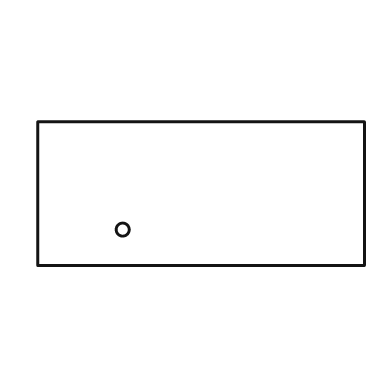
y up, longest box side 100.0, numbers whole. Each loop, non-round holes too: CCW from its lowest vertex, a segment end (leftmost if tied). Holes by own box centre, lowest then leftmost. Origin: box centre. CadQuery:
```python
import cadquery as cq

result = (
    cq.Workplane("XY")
    .moveTo(-50.0, -22.0)
    .lineTo(50.0, -22.0)
    .lineTo(50.0, 22.0)
    .lineTo(-50.0, 22.0)
    .close()
    .moveTo(-24.0, -11.0)
    .circle(2.0)
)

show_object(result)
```